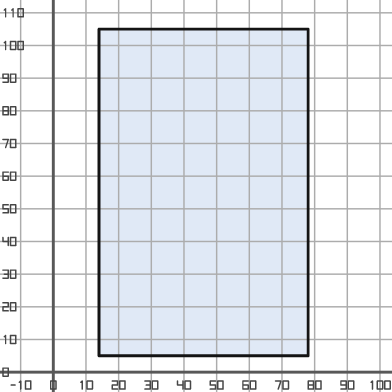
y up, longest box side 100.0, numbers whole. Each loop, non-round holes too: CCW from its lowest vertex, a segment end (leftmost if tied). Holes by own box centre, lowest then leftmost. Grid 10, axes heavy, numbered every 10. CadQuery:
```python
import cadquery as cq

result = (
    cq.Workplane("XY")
    .moveTo(14.0, 5.0)
    .lineTo(78.0, 5.0)
    .lineTo(78.0, 105.0)
    .lineTo(14.0, 105.0)
    .close()
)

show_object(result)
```